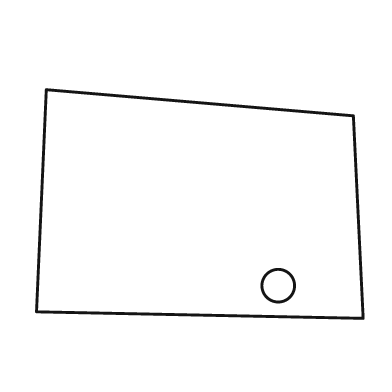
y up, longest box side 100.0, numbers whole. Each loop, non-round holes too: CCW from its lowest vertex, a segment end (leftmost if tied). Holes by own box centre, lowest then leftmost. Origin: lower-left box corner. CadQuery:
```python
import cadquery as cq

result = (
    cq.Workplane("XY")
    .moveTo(100.0, 0.0)
    .lineTo(97.0, 62.0)
    .lineTo(3.0, 70.0)
    .lineTo(0.0, 2.0)
    .close()
    .moveTo(74.0, 10.0)
    .circle(5.0)
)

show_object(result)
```